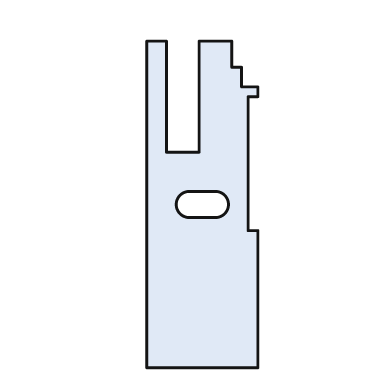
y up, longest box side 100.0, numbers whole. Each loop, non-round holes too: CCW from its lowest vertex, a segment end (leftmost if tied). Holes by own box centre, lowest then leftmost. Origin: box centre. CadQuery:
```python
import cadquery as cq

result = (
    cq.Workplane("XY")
    .moveTo(-17.0, -50.0)
    .lineTo(17.0, -50.0)
    .lineTo(17.0, -8.0)
    .lineTo(14.0, -8.0)
    .lineTo(14.0, 33.0)
    .lineTo(17.0, 33.0)
    .lineTo(17.0, 36.0)
    .lineTo(12.0, 36.0)
    .lineTo(12.0, 42.0)
    .lineTo(9.0, 42.0)
    .lineTo(9.0, 50.0)
    .lineTo(-1.0, 50.0)
    .lineTo(-1.0, 16.0)
    .lineTo(-11.0, 16.0)
    .lineTo(-11.0, 50.0)
    .lineTo(-17.0, 50.0)
    .close()
    .moveTo(-4.0, -4.0)
    .lineTo(4.0, -4.0)
    .threePointArc((8.0, 0.0), (4.0, 4.0))
    .lineTo(-4.0, 4.0)
    .threePointArc((-8.0, 0.0), (-4.0, -4.0))
    .close()
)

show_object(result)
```